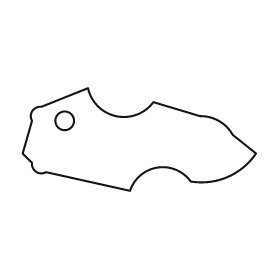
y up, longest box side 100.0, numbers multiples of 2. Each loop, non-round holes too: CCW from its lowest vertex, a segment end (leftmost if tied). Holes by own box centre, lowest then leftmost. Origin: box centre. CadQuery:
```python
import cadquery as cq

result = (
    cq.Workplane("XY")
    .moveTo(-4.0, -22.0)
    .threePointArc((8.0, -12.0), (22.0, -18.0))
    .threePointArc((38.0, -16.0), (50.0, -6.0))
    .lineTo(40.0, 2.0)
    .threePointArc((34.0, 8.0), (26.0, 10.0))
    .lineTo(6.0, 16.0)
    .threePointArc((-10.0, 10.0), (-22.0, 22.0))
    .lineTo(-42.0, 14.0)
    .threePointArc((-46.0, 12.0), (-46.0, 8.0))
    .lineTo(-50.0, -6.0)
    .lineTo(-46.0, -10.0)
    .threePointArc((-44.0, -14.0), (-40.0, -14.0))
    .close()
    .moveTo(-32.0, 8.0)
    .circle(4.0)
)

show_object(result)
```